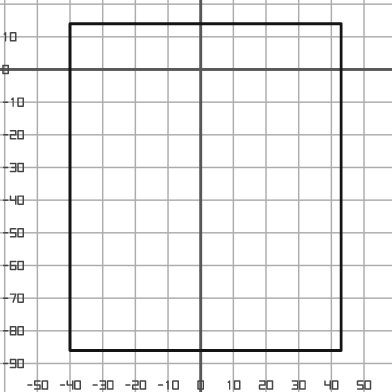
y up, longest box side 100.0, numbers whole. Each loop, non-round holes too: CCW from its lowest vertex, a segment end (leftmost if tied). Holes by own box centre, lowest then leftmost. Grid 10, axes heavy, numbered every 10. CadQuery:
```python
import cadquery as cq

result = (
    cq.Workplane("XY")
    .moveTo(-40.0, -86.0)
    .lineTo(43.0, -86.0)
    .lineTo(43.0, 14.0)
    .lineTo(-40.0, 14.0)
    .close()
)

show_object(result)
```